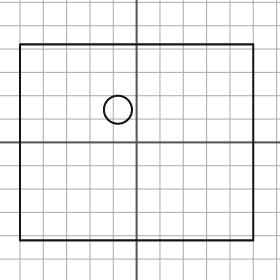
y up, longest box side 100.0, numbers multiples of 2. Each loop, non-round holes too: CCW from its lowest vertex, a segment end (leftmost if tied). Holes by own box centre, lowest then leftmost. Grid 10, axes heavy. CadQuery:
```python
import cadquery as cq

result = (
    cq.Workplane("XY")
    .moveTo(-50.0, -42.0)
    .lineTo(50.0, -42.0)
    .lineTo(50.0, 42.0)
    .lineTo(-50.0, 42.0)
    .close()
    .moveTo(-8.0, 14.0)
    .circle(6.0)
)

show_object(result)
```